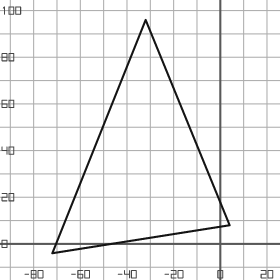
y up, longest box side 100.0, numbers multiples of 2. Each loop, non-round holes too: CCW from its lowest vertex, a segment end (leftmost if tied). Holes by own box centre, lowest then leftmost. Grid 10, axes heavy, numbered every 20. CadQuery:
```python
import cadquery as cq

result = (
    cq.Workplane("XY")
    .moveTo(-72.0, -4.0)
    .lineTo(4.0, 8.0)
    .lineTo(-32.0, 96.0)
    .close()
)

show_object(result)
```